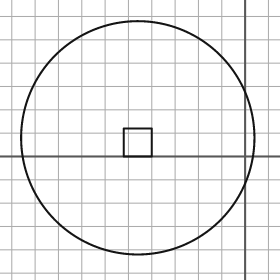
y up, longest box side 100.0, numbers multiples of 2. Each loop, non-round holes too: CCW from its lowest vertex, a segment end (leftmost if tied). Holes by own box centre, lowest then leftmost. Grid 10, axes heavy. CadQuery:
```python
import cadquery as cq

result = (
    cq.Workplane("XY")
    .moveTo(-46.0, 8.0)
    .circle(50.0)
    .moveTo(-52.0, 0.0)
    .lineTo(-40.0, 0.0)
    .lineTo(-40.0, 12.0)
    .lineTo(-52.0, 12.0)
    .close()
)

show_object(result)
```